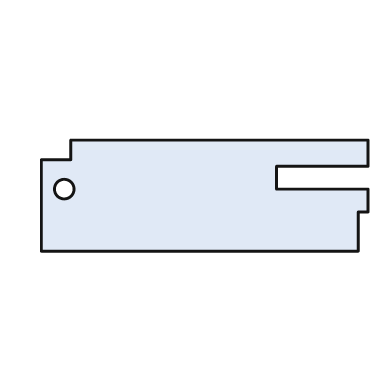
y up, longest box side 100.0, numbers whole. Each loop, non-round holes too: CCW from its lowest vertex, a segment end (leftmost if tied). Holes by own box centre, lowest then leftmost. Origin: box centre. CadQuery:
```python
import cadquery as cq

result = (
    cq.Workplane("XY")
    .moveTo(-50.0, -17.0)
    .lineTo(47.0, -17.0)
    .lineTo(47.0, -5.0)
    .lineTo(50.0, -5.0)
    .lineTo(50.0, 2.0)
    .lineTo(22.0, 2.0)
    .lineTo(22.0, 9.0)
    .lineTo(50.0, 9.0)
    .lineTo(50.0, 17.0)
    .lineTo(-41.0, 17.0)
    .lineTo(-41.0, 11.0)
    .lineTo(-50.0, 11.0)
    .close()
    .moveTo(-43.0, 2.0)
    .circle(3.0)
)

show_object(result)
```